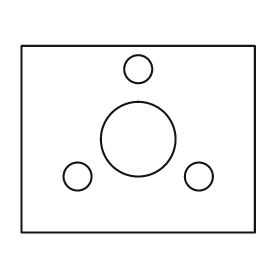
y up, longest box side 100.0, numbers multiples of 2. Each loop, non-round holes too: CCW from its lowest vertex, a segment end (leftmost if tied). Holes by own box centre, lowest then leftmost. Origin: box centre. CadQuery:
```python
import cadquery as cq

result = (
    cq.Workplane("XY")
    .moveTo(-50.0, -40.0)
    .lineTo(50.0, -40.0)
    .lineTo(50.0, 40.0)
    .lineTo(-50.0, 40.0)
    .close()
    .moveTo(-26.0, -16.0)
    .circle(6.0)
    .moveTo(26.0, -16.0)
    .circle(6.0)
    .moveTo(0.0, 0.0)
    .circle(16.0)
    .moveTo(0.0, 30.0)
    .circle(6.0)
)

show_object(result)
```